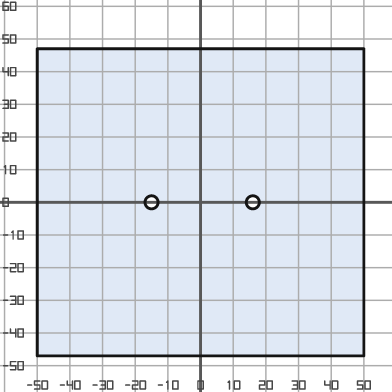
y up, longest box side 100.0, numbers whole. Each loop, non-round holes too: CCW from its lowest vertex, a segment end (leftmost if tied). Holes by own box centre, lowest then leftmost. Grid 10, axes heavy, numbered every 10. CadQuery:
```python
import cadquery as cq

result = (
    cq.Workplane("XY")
    .moveTo(-50.0, -47.0)
    .lineTo(50.0, -47.0)
    .lineTo(50.0, 47.0)
    .lineTo(-50.0, 47.0)
    .close()
    .moveTo(-15.0, 0.0)
    .circle(2.0)
    .moveTo(16.0, 0.0)
    .circle(2.0)
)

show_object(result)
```